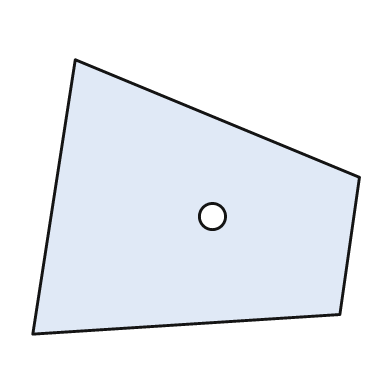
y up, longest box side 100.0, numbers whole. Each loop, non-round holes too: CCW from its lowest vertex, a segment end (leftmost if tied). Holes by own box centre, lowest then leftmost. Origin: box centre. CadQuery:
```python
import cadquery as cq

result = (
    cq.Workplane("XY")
    .moveTo(-50.0, -42.0)
    .lineTo(44.0, -36.0)
    .lineTo(50.0, 6.0)
    .lineTo(-37.0, 42.0)
    .close()
    .moveTo(5.0, -6.0)
    .circle(4.0)
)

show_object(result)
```